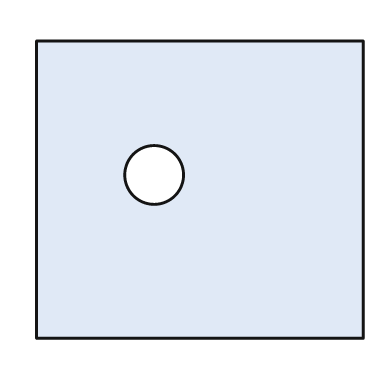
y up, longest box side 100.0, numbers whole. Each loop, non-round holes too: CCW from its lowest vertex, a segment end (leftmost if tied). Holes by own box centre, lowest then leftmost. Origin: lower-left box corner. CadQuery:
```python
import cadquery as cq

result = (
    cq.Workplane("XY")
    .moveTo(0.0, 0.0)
    .lineTo(100.0, 0.0)
    .lineTo(100.0, 91.0)
    .lineTo(0.0, 91.0)
    .close()
    .moveTo(36.0, 50.0)
    .circle(9.0)
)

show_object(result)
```